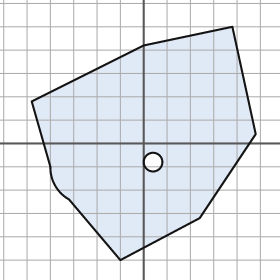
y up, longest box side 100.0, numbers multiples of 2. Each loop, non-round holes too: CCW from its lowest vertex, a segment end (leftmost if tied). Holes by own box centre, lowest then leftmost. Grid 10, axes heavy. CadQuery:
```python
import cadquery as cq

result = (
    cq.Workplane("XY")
    .moveTo(-10.0, -50.0)
    .lineTo(24.0, -32.0)
    .lineTo(48.0, 4.0)
    .lineTo(38.0, 50.0)
    .lineTo(0.0, 42.0)
    .lineTo(-48.0, 18.0)
    .lineTo(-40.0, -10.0)
    .threePointArc((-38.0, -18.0), (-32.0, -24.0))
    .close()
    .moveTo(4.0, -8.0)
    .circle(4.0)
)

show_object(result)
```